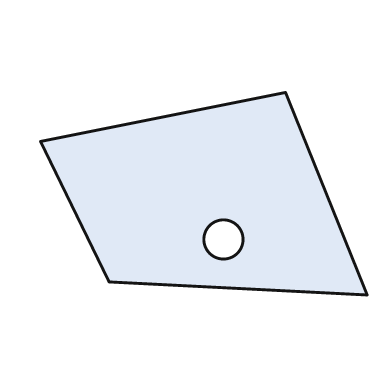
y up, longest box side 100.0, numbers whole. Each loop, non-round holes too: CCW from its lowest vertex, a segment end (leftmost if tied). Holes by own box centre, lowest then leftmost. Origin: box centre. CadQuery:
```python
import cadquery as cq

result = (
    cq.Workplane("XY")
    .moveTo(50.0, -31.0)
    .lineTo(25.0, 31.0)
    .lineTo(-50.0, 16.0)
    .lineTo(-29.0, -27.0)
    .close()
    .moveTo(6.0, -14.0)
    .circle(6.0)
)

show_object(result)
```